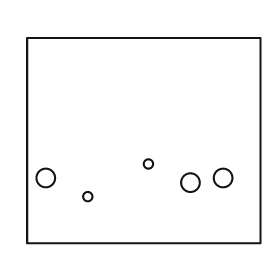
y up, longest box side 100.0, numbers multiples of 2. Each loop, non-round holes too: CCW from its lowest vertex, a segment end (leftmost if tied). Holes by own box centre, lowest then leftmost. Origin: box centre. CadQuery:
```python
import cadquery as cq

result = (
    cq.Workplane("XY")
    .moveTo(-50.0, -44.0)
    .lineTo(50.0, -44.0)
    .lineTo(50.0, 44.0)
    .lineTo(-50.0, 44.0)
    .close()
    .moveTo(-24.0, -24.0)
    .circle(2.0)
    .moveTo(20.0, -18.0)
    .circle(4.0)
    .moveTo(-42.0, -16.0)
    .circle(4.0)
    .moveTo(34.0, -16.0)
    .circle(4.0)
    .moveTo(2.0, -10.0)
    .circle(2.0)
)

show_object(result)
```